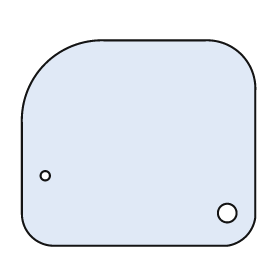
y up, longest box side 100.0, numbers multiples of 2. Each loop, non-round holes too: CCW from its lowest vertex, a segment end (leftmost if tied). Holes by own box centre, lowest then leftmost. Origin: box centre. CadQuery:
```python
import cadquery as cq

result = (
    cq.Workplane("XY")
    .moveTo(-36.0, -44.0)
    .lineTo(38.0, -44.0)
    .threePointArc((46.0, -40.0), (50.0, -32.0))
    .lineTo(50.0, 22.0)
    .threePointArc((44.0, 38.0), (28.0, 44.0))
    .lineTo(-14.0, 44.0)
    .threePointArc((-40.0, 34.0), (-50.0, 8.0))
    .lineTo(-50.0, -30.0)
    .threePointArc((-46.0, -40.0), (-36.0, -44.0))
    .close()
    .moveTo(38.0, -30.0)
    .circle(4.0)
    .moveTo(-40.0, -14.0)
    .circle(2.0)
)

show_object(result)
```